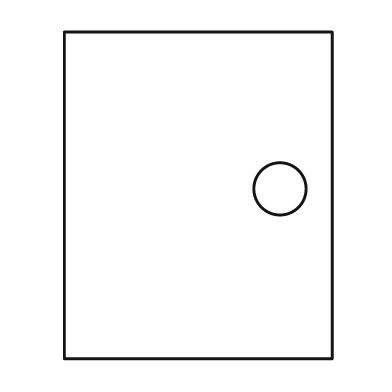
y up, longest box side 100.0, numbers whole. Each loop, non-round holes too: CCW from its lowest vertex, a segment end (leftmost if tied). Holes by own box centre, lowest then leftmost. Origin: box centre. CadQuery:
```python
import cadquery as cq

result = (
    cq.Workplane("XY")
    .moveTo(-41.0, -50.0)
    .lineTo(41.0, -50.0)
    .lineTo(41.0, 50.0)
    .lineTo(-41.0, 50.0)
    .close()
    .moveTo(25.0, 2.0)
    .circle(8.0)
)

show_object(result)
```